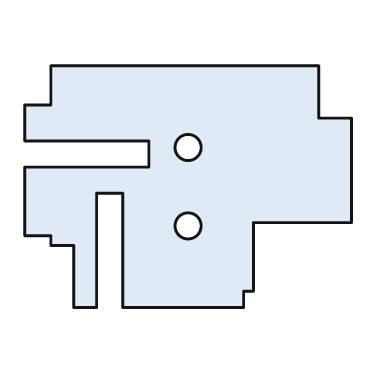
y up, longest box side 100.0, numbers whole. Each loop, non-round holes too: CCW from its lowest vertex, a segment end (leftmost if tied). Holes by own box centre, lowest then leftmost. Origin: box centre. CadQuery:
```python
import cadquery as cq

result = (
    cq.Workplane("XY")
    .moveTo(-35.0, -37.0)
    .lineTo(-28.0, -37.0)
    .lineTo(-28.0, -2.0)
    .lineTo(-20.0, -2.0)
    .lineTo(-20.0, -37.0)
    .lineTo(17.0, -37.0)
    .lineTo(17.0, -32.0)
    .lineTo(20.0, -32.0)
    .lineTo(20.0, -11.0)
    .lineTo(50.0, -11.0)
    .lineTo(50.0, 21.0)
    .lineTo(40.0, 21.0)
    .lineTo(40.0, 37.0)
    .lineTo(-42.0, 37.0)
    .lineTo(-42.0, 25.0)
    .lineTo(-50.0, 25.0)
    .lineTo(-50.0, 14.0)
    .lineTo(-12.0, 14.0)
    .lineTo(-12.0, 6.0)
    .lineTo(-50.0, 6.0)
    .lineTo(-50.0, -15.0)
    .lineTo(-42.0, -15.0)
    .lineTo(-42.0, -18.0)
    .lineTo(-35.0, -18.0)
    .close()
    .moveTo(0.0, -12.0)
    .circle(4.0)
    .moveTo(0.0, 12.0)
    .circle(4.0)
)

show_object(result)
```